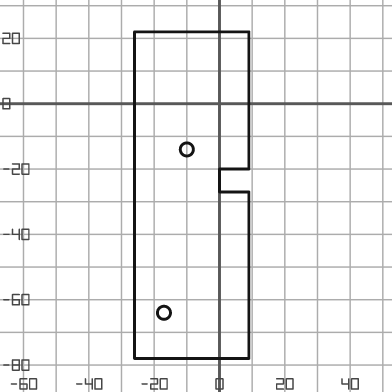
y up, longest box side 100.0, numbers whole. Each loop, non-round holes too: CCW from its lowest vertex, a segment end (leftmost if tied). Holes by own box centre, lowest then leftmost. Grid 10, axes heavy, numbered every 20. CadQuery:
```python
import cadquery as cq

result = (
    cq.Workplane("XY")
    .moveTo(-26.0, -78.0)
    .lineTo(9.0, -78.0)
    .lineTo(9.0, -27.0)
    .lineTo(0.0, -27.0)
    .lineTo(0.0, -20.0)
    .lineTo(9.0, -20.0)
    .lineTo(9.0, 22.0)
    .lineTo(-26.0, 22.0)
    .close()
    .moveTo(-17.0, -64.0)
    .circle(2.0)
    .moveTo(-10.0, -14.0)
    .circle(2.0)
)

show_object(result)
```